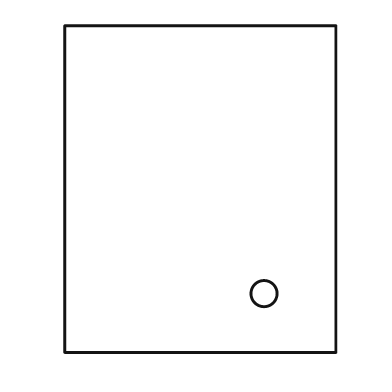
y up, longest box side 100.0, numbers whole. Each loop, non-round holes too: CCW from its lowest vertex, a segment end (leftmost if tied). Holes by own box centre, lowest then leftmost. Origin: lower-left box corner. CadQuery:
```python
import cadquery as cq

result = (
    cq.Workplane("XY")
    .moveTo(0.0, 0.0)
    .lineTo(83.0, 0.0)
    .lineTo(83.0, 100.0)
    .lineTo(0.0, 100.0)
    .close()
    .moveTo(61.0, 18.0)
    .circle(4.0)
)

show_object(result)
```